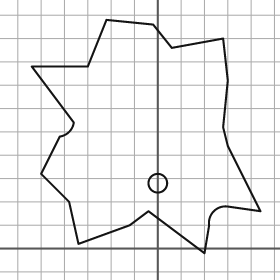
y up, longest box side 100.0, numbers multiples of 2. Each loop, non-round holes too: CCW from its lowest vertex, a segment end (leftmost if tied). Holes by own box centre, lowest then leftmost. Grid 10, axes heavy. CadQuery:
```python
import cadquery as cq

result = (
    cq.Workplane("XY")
    .moveTo(20.0, -2.0)
    .lineTo(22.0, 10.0)
    .threePointArc((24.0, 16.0), (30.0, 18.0))
    .lineTo(44.0, 16.0)
    .lineTo(30.0, 44.0)
    .lineTo(28.0, 52.0)
    .lineTo(30.0, 72.0)
    .lineTo(28.0, 90.0)
    .lineTo(6.0, 86.0)
    .lineTo(-2.0, 96.0)
    .lineTo(-22.0, 98.0)
    .lineTo(-30.0, 78.0)
    .lineTo(-54.0, 78.0)
    .lineTo(-36.0, 54.0)
    .threePointArc((-38.0, 50.0), (-42.0, 48.0))
    .lineTo(-50.0, 32.0)
    .lineTo(-38.0, 20.0)
    .lineTo(-34.0, 2.0)
    .lineTo(-12.0, 10.0)
    .lineTo(-4.0, 16.0)
    .close()
    .moveTo(0.0, 28.0)
    .circle(4.0)
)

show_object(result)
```